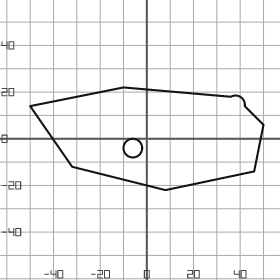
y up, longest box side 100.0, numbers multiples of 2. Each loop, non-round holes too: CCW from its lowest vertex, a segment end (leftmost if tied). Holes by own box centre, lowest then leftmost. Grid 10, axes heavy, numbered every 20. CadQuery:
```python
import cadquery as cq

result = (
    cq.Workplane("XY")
    .moveTo(8.0, -22.0)
    .lineTo(46.0, -14.0)
    .lineTo(50.0, 6.0)
    .lineTo(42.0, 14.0)
    .threePointArc((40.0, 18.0), (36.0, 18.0))
    .lineTo(-10.0, 22.0)
    .lineTo(-50.0, 14.0)
    .lineTo(-32.0, -12.0)
    .close()
    .moveTo(-6.0, -4.0)
    .circle(4.0)
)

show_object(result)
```